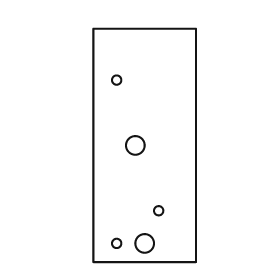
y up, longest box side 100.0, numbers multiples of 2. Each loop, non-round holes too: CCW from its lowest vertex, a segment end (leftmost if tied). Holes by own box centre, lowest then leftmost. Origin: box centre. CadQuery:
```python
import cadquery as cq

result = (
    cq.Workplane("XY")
    .moveTo(-22.0, -50.0)
    .lineTo(22.0, -50.0)
    .lineTo(22.0, 50.0)
    .lineTo(-22.0, 50.0)
    .close()
    .moveTo(-12.0, -42.0)
    .circle(2.0)
    .moveTo(0.0, -42.0)
    .circle(4.0)
    .moveTo(6.0, -28.0)
    .circle(2.0)
    .moveTo(-4.0, 0.0)
    .circle(4.0)
    .moveTo(-12.0, 28.0)
    .circle(2.0)
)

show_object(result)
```